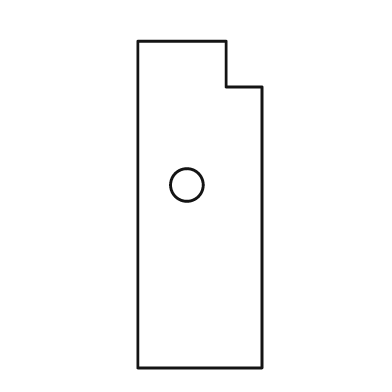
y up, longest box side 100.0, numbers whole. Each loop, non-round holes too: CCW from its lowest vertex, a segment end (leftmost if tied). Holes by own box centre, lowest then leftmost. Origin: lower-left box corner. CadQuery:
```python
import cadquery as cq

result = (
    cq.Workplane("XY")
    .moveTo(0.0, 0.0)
    .lineTo(38.0, 0.0)
    .lineTo(38.0, 86.0)
    .lineTo(27.0, 86.0)
    .lineTo(27.0, 100.0)
    .lineTo(0.0, 100.0)
    .close()
    .moveTo(15.0, 56.0)
    .circle(5.0)
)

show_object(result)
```